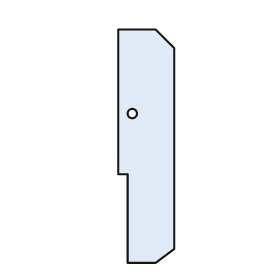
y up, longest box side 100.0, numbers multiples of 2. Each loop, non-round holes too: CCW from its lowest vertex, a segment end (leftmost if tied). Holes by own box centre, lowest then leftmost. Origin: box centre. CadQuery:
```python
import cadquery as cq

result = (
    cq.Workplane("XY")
    .moveTo(-8.0, -50.0)
    .lineTo(4.0, -50.0)
    .lineTo(12.0, -44.0)
    .lineTo(12.0, 42.0)
    .lineTo(4.0, 50.0)
    .lineTo(-12.0, 50.0)
    .lineTo(-12.0, -12.0)
    .lineTo(-8.0, -12.0)
    .close()
    .moveTo(-6.0, 14.0)
    .circle(2.0)
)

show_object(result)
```